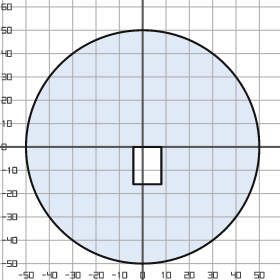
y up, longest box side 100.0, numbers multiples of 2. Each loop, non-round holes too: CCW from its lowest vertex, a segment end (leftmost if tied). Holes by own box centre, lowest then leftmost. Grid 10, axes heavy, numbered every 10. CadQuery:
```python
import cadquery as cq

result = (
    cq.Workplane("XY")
    .moveTo(0.0, 0.0)
    .circle(50.0)
    .moveTo(-4.0, -16.0)
    .lineTo(8.0, -16.0)
    .lineTo(8.0, 0.0)
    .lineTo(-4.0, 0.0)
    .close()
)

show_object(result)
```